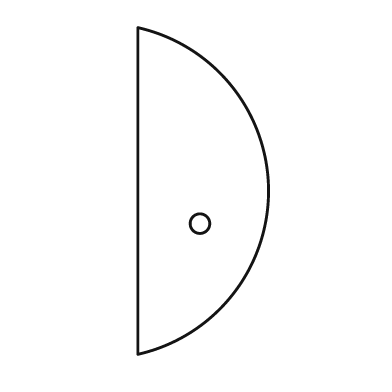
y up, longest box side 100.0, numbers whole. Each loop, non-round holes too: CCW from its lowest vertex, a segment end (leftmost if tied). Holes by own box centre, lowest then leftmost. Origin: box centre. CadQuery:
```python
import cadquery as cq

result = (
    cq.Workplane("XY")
    .moveTo(-20.0, -50.0)
    .threePointArc((20.0, 0.0), (-20.0, 50.0))
    .close()
    .moveTo(-1.0, -10.0)
    .circle(3.0)
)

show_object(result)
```